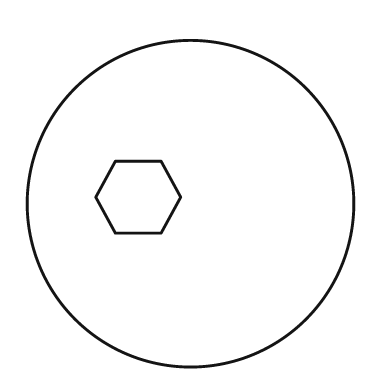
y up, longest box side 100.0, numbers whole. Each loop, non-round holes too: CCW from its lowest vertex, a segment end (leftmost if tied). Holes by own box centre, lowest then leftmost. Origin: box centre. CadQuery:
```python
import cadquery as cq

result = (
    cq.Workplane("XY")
    .moveTo(0.0, 0.0)
    .circle(50.0)
    .moveTo(-23.0, -9.0)
    .lineTo(-9.0, -9.0)
    .lineTo(-3.0, 2.0)
    .lineTo(-9.0, 13.0)
    .lineTo(-23.0, 13.0)
    .lineTo(-29.0, 2.0)
    .close()
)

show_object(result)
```